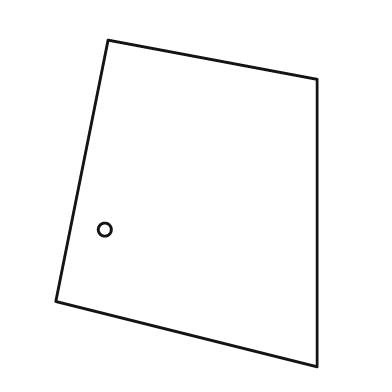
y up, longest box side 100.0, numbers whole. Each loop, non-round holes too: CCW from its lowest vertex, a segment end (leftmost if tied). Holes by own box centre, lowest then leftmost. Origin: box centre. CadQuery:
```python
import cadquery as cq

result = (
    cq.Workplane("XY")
    .moveTo(40.0, -50.0)
    .lineTo(40.0, 38.0)
    .lineTo(-24.0, 50.0)
    .lineTo(-40.0, -30.0)
    .close()
    .moveTo(-25.0, -8.0)
    .circle(2.0)
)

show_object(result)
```